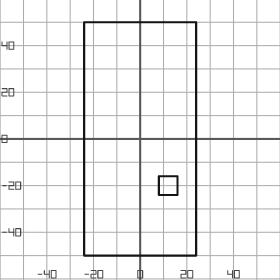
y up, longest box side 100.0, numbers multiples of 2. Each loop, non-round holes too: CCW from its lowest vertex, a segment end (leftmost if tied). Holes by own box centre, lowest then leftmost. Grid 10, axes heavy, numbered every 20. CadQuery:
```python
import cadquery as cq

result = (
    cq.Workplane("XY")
    .moveTo(-24.0, -50.0)
    .lineTo(24.0, -50.0)
    .lineTo(24.0, 50.0)
    .lineTo(-24.0, 50.0)
    .close()
    .moveTo(8.0, -24.0)
    .lineTo(16.0, -24.0)
    .lineTo(16.0, -16.0)
    .lineTo(8.0, -16.0)
    .close()
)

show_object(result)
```